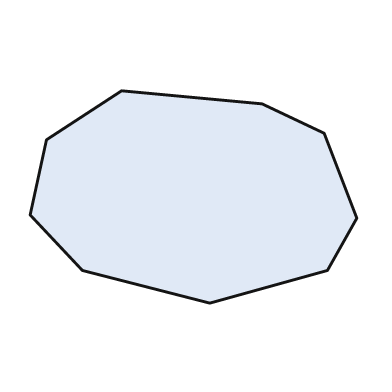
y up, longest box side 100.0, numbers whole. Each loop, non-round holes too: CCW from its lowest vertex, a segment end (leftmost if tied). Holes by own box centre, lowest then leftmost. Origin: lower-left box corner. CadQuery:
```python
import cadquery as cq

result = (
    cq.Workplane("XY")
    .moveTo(55.0, 0.0)
    .lineTo(91.0, 10.0)
    .lineTo(100.0, 26.0)
    .lineTo(90.0, 52.0)
    .lineTo(71.0, 61.0)
    .lineTo(28.0, 65.0)
    .lineTo(5.0, 50.0)
    .lineTo(0.0, 27.0)
    .lineTo(16.0, 10.0)
    .close()
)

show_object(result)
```